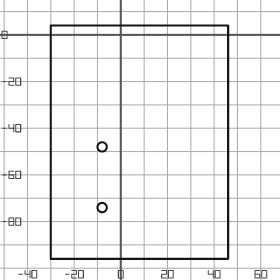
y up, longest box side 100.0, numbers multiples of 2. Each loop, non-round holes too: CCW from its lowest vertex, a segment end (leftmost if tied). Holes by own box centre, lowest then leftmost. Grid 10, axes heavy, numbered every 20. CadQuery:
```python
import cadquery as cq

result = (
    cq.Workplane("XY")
    .moveTo(-30.0, -96.0)
    .lineTo(46.0, -96.0)
    .lineTo(46.0, 4.0)
    .lineTo(-30.0, 4.0)
    .close()
    .moveTo(-8.0, -74.0)
    .circle(2.0)
    .moveTo(-8.0, -48.0)
    .circle(2.0)
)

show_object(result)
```